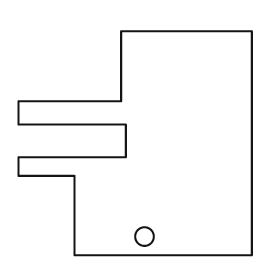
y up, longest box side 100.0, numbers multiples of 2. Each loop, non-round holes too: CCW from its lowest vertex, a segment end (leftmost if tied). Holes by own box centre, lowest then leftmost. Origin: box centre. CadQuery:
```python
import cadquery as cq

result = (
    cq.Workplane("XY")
    .moveTo(-26.0, -48.0)
    .lineTo(50.0, -48.0)
    .lineTo(50.0, 48.0)
    .lineTo(-6.0, 48.0)
    .lineTo(-6.0, 18.0)
    .lineTo(-50.0, 18.0)
    .lineTo(-50.0, 8.0)
    .lineTo(-4.0, 8.0)
    .lineTo(-4.0, -6.0)
    .lineTo(-50.0, -6.0)
    .lineTo(-50.0, -14.0)
    .lineTo(-26.0, -14.0)
    .close()
    .moveTo(4.0, -40.0)
    .circle(4.0)
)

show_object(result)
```